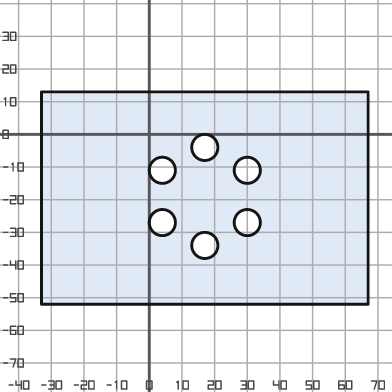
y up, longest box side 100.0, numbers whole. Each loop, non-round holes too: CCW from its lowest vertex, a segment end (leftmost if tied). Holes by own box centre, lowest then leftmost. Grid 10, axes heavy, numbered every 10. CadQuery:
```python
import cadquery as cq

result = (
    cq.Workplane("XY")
    .moveTo(-33.0, -52.0)
    .lineTo(67.0, -52.0)
    .lineTo(67.0, 13.0)
    .lineTo(-33.0, 13.0)
    .close()
    .moveTo(17.0, -34.0)
    .circle(4.0)
    .moveTo(4.0, -27.0)
    .circle(4.0)
    .moveTo(30.0, -27.0)
    .circle(4.0)
    .moveTo(4.0, -11.0)
    .circle(4.0)
    .moveTo(30.0, -11.0)
    .circle(4.0)
    .moveTo(17.0, -4.0)
    .circle(4.0)
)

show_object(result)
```